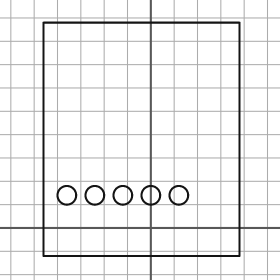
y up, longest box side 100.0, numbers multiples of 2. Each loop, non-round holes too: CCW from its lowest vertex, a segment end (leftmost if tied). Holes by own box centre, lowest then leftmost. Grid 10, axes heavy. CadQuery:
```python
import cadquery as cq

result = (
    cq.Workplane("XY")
    .moveTo(-46.0, -12.0)
    .lineTo(38.0, -12.0)
    .lineTo(38.0, 88.0)
    .lineTo(-46.0, 88.0)
    .close()
    .moveTo(-36.0, 14.0)
    .circle(4.0)
    .moveTo(-24.0, 14.0)
    .circle(4.0)
    .moveTo(-12.0, 14.0)
    .circle(4.0)
    .moveTo(0.0, 14.0)
    .circle(4.0)
    .moveTo(12.0, 14.0)
    .circle(4.0)
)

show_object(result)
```